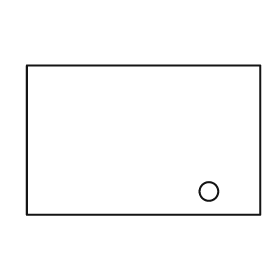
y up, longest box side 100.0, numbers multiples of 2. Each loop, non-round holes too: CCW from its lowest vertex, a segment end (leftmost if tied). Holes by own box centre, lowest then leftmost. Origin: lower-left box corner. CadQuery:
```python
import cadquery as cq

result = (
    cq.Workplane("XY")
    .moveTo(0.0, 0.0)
    .lineTo(100.0, 0.0)
    .lineTo(100.0, 64.0)
    .lineTo(0.0, 64.0)
    .close()
    .moveTo(78.0, 10.0)
    .circle(4.0)
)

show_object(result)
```